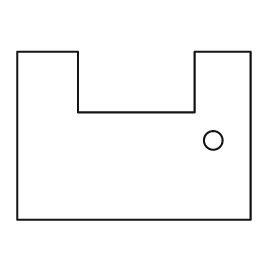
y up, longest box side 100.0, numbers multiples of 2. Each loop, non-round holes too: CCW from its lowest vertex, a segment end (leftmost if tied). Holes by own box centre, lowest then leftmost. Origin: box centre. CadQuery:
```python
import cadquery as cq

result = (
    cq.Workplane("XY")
    .moveTo(-50.0, -36.0)
    .lineTo(50.0, -36.0)
    .lineTo(50.0, 36.0)
    .lineTo(26.0, 36.0)
    .lineTo(26.0, 10.0)
    .lineTo(-24.0, 10.0)
    .lineTo(-24.0, 36.0)
    .lineTo(-50.0, 36.0)
    .close()
    .moveTo(34.0, -2.0)
    .circle(4.0)
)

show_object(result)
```